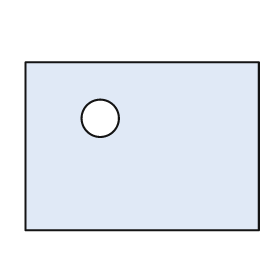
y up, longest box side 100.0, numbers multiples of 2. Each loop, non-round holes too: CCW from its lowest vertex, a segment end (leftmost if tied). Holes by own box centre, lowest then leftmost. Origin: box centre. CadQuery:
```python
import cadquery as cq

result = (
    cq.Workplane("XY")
    .moveTo(-50.0, -36.0)
    .lineTo(50.0, -36.0)
    .lineTo(50.0, 36.0)
    .lineTo(-50.0, 36.0)
    .close()
    .moveTo(-18.0, 12.0)
    .circle(8.0)
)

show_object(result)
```